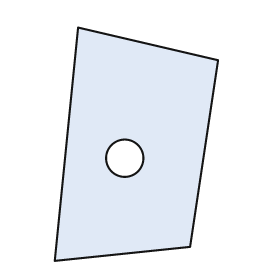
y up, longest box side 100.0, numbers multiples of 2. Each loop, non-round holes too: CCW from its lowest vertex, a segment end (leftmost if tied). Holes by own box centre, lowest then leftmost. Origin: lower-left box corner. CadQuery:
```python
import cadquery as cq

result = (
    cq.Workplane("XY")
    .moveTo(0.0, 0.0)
    .lineTo(58.0, 6.0)
    .lineTo(70.0, 86.0)
    .lineTo(10.0, 100.0)
    .close()
    .moveTo(30.0, 44.0)
    .circle(8.0)
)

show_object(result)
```